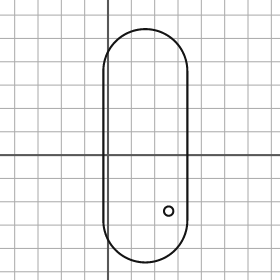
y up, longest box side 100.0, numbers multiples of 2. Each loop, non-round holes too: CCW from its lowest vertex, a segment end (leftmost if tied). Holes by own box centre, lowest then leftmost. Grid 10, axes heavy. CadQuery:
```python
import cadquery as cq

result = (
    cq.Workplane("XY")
    .moveTo(-2.0, -28.0)
    .threePointArc((16.0, -46.0), (34.0, -28.0))
    .lineTo(34.0, 36.0)
    .threePointArc((16.0, 54.0), (-2.0, 36.0))
    .close()
    .moveTo(26.0, -24.0)
    .circle(2.0)
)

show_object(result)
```